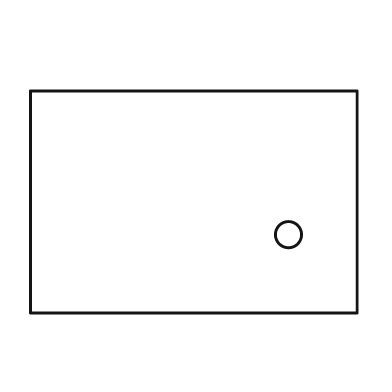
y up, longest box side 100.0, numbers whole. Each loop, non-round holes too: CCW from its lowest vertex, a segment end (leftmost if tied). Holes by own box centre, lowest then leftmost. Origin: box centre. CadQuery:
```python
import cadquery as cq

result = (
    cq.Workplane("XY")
    .moveTo(-50.0, -34.0)
    .lineTo(50.0, -34.0)
    .lineTo(50.0, 34.0)
    .lineTo(-50.0, 34.0)
    .close()
    .moveTo(29.0, -10.0)
    .circle(4.0)
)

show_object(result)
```